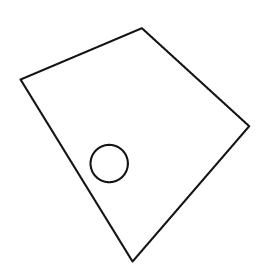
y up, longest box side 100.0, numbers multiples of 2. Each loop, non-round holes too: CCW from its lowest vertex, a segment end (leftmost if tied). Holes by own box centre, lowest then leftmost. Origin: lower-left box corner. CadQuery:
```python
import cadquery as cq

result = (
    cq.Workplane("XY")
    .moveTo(48.0, 0.0)
    .lineTo(98.0, 58.0)
    .lineTo(52.0, 100.0)
    .lineTo(0.0, 78.0)
    .close()
    .moveTo(38.0, 42.0)
    .circle(8.0)
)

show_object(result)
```